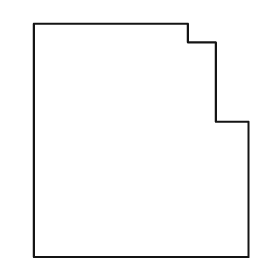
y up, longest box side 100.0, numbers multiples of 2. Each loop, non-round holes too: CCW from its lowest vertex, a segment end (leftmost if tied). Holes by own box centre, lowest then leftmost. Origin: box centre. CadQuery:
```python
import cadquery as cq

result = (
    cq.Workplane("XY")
    .moveTo(-46.0, -50.0)
    .lineTo(46.0, -50.0)
    .lineTo(46.0, 8.0)
    .lineTo(32.0, 8.0)
    .lineTo(32.0, 42.0)
    .lineTo(20.0, 42.0)
    .lineTo(20.0, 50.0)
    .lineTo(-46.0, 50.0)
    .close()
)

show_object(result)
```